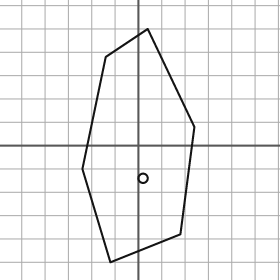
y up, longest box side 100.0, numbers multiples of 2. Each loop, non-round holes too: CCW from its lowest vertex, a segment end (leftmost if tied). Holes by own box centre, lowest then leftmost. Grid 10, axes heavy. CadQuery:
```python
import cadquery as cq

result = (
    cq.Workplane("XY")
    .moveTo(-12.0, -50.0)
    .lineTo(18.0, -38.0)
    .lineTo(24.0, 8.0)
    .lineTo(4.0, 50.0)
    .lineTo(-14.0, 38.0)
    .lineTo(-24.0, -10.0)
    .close()
    .moveTo(2.0, -14.0)
    .circle(2.0)
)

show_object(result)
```